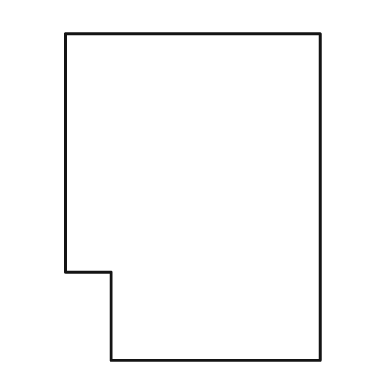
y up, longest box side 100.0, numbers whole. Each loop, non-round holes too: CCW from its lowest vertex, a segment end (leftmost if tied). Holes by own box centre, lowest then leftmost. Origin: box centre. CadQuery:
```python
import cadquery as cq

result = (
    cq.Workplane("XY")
    .moveTo(-25.0, -50.0)
    .lineTo(39.0, -50.0)
    .lineTo(39.0, 50.0)
    .lineTo(-39.0, 50.0)
    .lineTo(-39.0, -23.0)
    .lineTo(-25.0, -23.0)
    .close()
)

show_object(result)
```